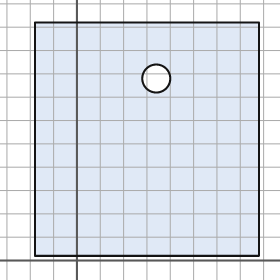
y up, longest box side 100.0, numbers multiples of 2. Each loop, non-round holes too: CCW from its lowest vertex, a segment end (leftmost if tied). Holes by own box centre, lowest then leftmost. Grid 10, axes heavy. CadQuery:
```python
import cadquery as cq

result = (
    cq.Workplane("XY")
    .moveTo(-18.0, 2.0)
    .lineTo(78.0, 2.0)
    .lineTo(78.0, 102.0)
    .lineTo(-18.0, 102.0)
    .close()
    .moveTo(34.0, 78.0)
    .circle(6.0)
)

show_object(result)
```